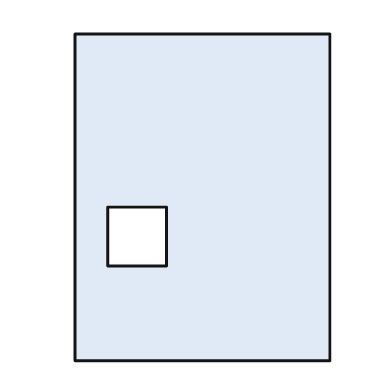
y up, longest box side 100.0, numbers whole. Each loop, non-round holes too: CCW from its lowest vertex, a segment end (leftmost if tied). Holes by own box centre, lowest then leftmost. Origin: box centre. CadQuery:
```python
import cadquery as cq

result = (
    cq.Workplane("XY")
    .moveTo(-39.0, -50.0)
    .lineTo(39.0, -50.0)
    .lineTo(39.0, 50.0)
    .lineTo(-39.0, 50.0)
    .close()
    .moveTo(-29.0, -21.0)
    .lineTo(-11.0, -21.0)
    .lineTo(-11.0, -3.0)
    .lineTo(-29.0, -3.0)
    .close()
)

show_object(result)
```